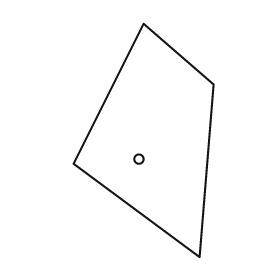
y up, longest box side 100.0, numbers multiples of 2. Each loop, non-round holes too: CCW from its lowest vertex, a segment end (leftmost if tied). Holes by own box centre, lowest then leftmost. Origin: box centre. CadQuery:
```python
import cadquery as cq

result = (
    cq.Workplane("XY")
    .moveTo(24.0, -50.0)
    .lineTo(30.0, 24.0)
    .lineTo(0.0, 50.0)
    .lineTo(-30.0, -10.0)
    .close()
    .moveTo(-2.0, -8.0)
    .circle(2.0)
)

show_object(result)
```